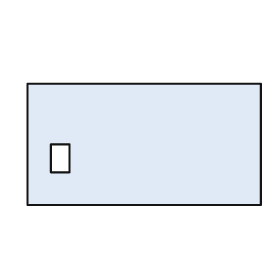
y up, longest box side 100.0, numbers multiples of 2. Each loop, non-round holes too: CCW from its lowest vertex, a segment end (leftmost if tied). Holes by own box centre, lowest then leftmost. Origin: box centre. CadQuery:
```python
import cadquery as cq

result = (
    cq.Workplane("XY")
    .moveTo(-50.0, -26.0)
    .lineTo(50.0, -26.0)
    .lineTo(50.0, 26.0)
    .lineTo(-50.0, 26.0)
    .close()
    .moveTo(-40.0, -12.0)
    .lineTo(-32.0, -12.0)
    .lineTo(-32.0, 0.0)
    .lineTo(-40.0, 0.0)
    .close()
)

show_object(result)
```